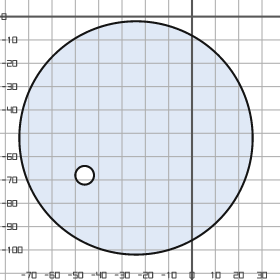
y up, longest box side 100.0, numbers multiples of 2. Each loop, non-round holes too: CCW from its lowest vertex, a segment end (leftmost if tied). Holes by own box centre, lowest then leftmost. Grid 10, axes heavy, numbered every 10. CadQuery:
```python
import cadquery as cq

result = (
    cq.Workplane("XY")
    .moveTo(-24.0, -52.0)
    .circle(50.0)
    .moveTo(-46.0, -68.0)
    .circle(4.0)
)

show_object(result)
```